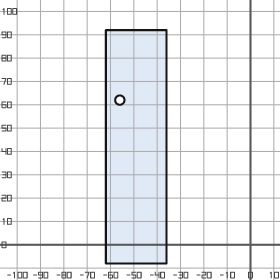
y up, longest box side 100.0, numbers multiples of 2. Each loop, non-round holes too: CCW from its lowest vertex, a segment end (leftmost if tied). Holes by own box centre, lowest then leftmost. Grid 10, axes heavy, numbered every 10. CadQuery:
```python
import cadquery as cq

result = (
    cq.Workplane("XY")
    .moveTo(-62.0, -8.0)
    .lineTo(-36.0, -8.0)
    .lineTo(-36.0, 92.0)
    .lineTo(-62.0, 92.0)
    .close()
    .moveTo(-56.0, 62.0)
    .circle(2.0)
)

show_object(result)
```